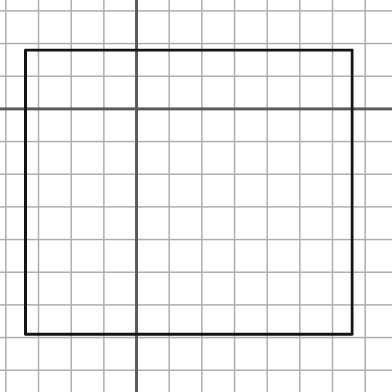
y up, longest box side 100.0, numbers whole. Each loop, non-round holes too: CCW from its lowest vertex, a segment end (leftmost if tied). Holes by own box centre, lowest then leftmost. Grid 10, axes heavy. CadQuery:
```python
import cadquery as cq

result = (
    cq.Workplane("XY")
    .moveTo(-34.0, -69.0)
    .lineTo(66.0, -69.0)
    .lineTo(66.0, 18.0)
    .lineTo(-34.0, 18.0)
    .close()
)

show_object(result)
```